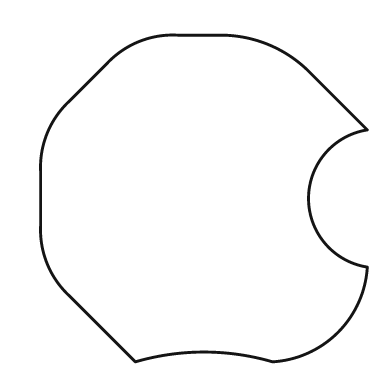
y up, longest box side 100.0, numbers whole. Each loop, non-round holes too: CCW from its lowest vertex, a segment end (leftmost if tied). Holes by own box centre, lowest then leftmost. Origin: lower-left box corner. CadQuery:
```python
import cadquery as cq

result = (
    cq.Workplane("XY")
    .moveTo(29.0, 0.0)
    .threePointArc((50.0, 3.0), (71.0, 0.0))
    .threePointArc((91.0, 9.0), (100.0, 29.0))
    .threePointArc((82.0, 50.0), (100.0, 71.0))
    .lineTo(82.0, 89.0)
    .threePointArc((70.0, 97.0), (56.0, 100.0))
    .lineTo(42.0, 100.0)
    .threePointArc((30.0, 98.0), (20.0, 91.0))
    .lineTo(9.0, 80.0)
    .threePointArc((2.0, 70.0), (0.0, 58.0))
    .lineTo(0.0, 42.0)
    .threePointArc((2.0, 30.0), (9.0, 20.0))
    .close()
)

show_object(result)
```